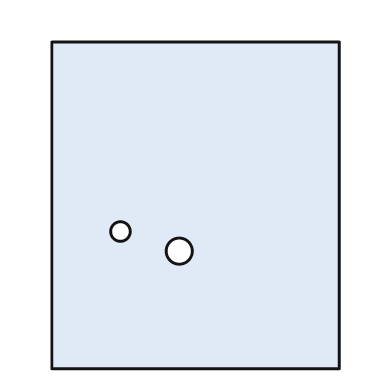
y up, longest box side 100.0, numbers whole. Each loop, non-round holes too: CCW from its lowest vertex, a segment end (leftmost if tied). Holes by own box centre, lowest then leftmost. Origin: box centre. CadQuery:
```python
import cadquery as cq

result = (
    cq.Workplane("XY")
    .moveTo(-44.0, -50.0)
    .lineTo(44.0, -50.0)
    .lineTo(44.0, 50.0)
    .lineTo(-44.0, 50.0)
    .close()
    .moveTo(-5.0, -14.0)
    .circle(4.0)
    .moveTo(-23.0, -8.0)
    .circle(3.0)
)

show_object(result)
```